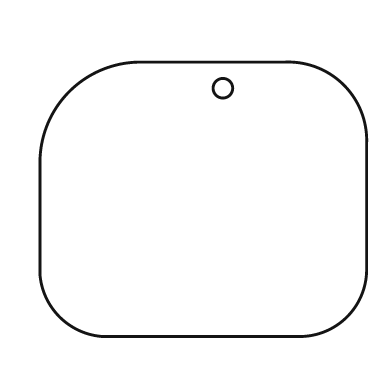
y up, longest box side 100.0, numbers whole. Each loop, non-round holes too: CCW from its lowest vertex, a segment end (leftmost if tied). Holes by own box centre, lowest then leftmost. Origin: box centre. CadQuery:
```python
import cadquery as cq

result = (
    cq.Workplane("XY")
    .moveTo(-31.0, -42.0)
    .lineTo(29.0, -42.0)
    .threePointArc((44.0, -36.0), (50.0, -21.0))
    .lineTo(50.0, 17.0)
    .threePointArc((43.0, 35.0), (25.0, 42.0))
    .lineTo(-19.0, 42.0)
    .threePointArc((-41.0, 33.0), (-50.0, 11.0))
    .lineTo(-50.0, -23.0)
    .threePointArc((-44.0, -36.0), (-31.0, -42.0))
    .close()
    .moveTo(6.0, 34.0)
    .circle(3.0)
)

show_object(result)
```